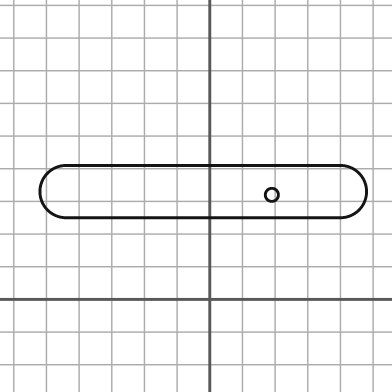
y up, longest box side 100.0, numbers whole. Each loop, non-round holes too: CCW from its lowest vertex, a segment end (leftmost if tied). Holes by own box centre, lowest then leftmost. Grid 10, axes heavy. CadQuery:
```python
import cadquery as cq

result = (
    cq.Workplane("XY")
    .moveTo(-44.0, 25.0)
    .lineTo(40.0, 25.0)
    .threePointArc((48.0, 33.0), (40.0, 41.0))
    .lineTo(-44.0, 41.0)
    .threePointArc((-52.0, 33.0), (-44.0, 25.0))
    .close()
    .moveTo(19.0, 32.0)
    .circle(2.0)
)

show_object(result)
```